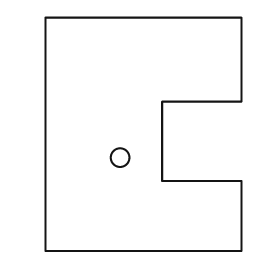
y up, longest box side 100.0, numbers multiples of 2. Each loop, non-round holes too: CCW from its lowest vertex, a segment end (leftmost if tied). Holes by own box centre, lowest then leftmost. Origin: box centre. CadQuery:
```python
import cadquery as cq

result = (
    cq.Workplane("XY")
    .moveTo(-42.0, -50.0)
    .lineTo(42.0, -50.0)
    .lineTo(42.0, -20.0)
    .lineTo(8.0, -20.0)
    .lineTo(8.0, 14.0)
    .lineTo(42.0, 14.0)
    .lineTo(42.0, 50.0)
    .lineTo(-42.0, 50.0)
    .close()
    .moveTo(-10.0, -10.0)
    .circle(4.0)
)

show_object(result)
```